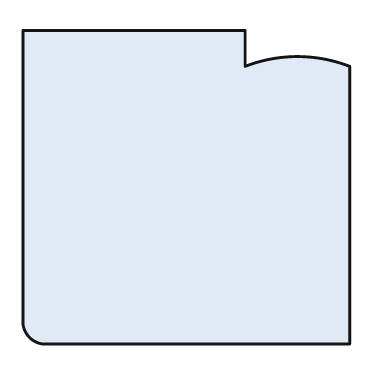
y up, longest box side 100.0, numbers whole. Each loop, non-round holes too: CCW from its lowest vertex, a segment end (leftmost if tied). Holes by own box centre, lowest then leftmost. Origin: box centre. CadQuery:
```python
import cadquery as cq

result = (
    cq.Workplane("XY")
    .moveTo(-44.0, -48.0)
    .lineTo(50.0, -48.0)
    .lineTo(50.0, 37.0)
    .threePointArc((34.0, 40.0), (18.0, 37.0))
    .lineTo(18.0, 48.0)
    .lineTo(-50.0, 48.0)
    .lineTo(-50.0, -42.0)
    .threePointArc((-48.0, -46.0), (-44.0, -48.0))
    .close()
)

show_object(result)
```